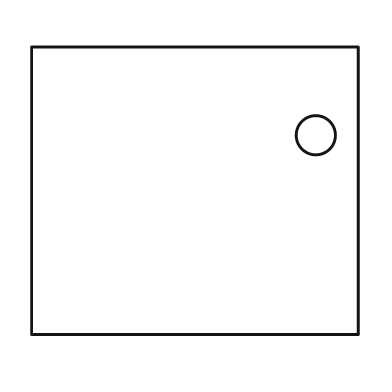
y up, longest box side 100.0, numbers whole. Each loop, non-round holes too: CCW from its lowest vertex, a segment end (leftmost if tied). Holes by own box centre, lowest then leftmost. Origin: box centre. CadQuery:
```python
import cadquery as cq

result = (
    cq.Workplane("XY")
    .moveTo(-50.0, -44.0)
    .lineTo(50.0, -44.0)
    .lineTo(50.0, 44.0)
    .lineTo(-50.0, 44.0)
    .close()
    .moveTo(37.0, 17.0)
    .circle(6.0)
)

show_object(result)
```